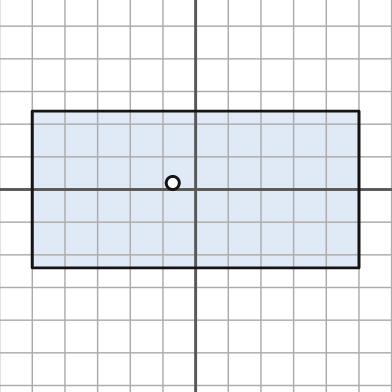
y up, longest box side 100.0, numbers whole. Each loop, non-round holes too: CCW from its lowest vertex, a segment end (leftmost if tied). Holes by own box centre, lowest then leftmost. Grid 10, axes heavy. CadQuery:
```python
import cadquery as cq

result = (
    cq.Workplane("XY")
    .moveTo(-50.0, -24.0)
    .lineTo(50.0, -24.0)
    .lineTo(50.0, 24.0)
    .lineTo(-50.0, 24.0)
    .close()
    .moveTo(-7.0, 2.0)
    .circle(2.0)
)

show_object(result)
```